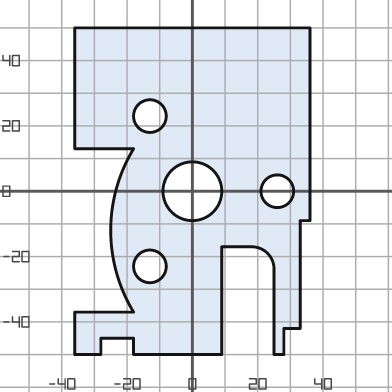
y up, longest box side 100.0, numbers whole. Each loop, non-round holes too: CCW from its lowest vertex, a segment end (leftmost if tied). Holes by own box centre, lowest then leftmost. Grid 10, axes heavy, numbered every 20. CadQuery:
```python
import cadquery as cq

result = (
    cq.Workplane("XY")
    .moveTo(-36.0, -50.0)
    .lineTo(-28.0, -50.0)
    .lineTo(-28.0, -45.0)
    .lineTo(-18.0, -45.0)
    .lineTo(-18.0, -50.0)
    .lineTo(9.0, -50.0)
    .lineTo(9.0, -17.0)
    .lineTo(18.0, -17.0)
    .threePointArc((23.0, -19.0), (25.0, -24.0))
    .lineTo(25.0, -50.0)
    .lineTo(28.0, -50.0)
    .lineTo(28.0, -42.0)
    .lineTo(33.0, -42.0)
    .lineTo(33.0, -9.0)
    .lineTo(36.0, -9.0)
    .lineTo(36.0, 50.0)
    .lineTo(-36.0, 50.0)
    .lineTo(-36.0, 13.0)
    .lineTo(-18.0, 13.0)
    .threePointArc((-25.0, -12.0), (-18.0, -37.0))
    .lineTo(-36.0, -37.0)
    .close()
    .moveTo(-13.0, -23.0)
    .circle(5.0)
    .moveTo(0.0, 0.0)
    .circle(9.0)
    .moveTo(26.0, 0.0)
    .circle(5.0)
    .moveTo(-13.0, 23.0)
    .circle(5.0)
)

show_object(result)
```